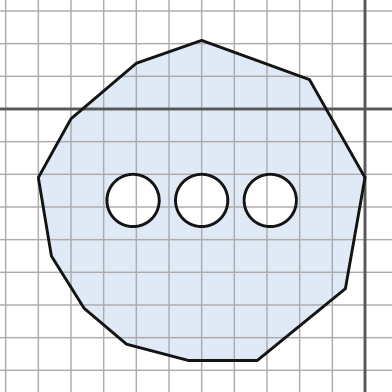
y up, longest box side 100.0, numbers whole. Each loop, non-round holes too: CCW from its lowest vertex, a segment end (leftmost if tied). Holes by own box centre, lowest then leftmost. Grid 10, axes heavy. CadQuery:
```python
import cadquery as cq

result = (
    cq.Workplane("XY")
    .moveTo(-54.0, -77.0)
    .lineTo(-33.0, -77.0)
    .lineTo(-6.0, -55.0)
    .lineTo(0.0, -21.0)
    .lineTo(-17.0, 9.0)
    .lineTo(-50.0, 21.0)
    .lineTo(-70.0, 14.0)
    .lineTo(-90.0, -3.0)
    .lineTo(-100.0, -21.0)
    .lineTo(-96.0, -45.0)
    .lineTo(-86.0, -61.0)
    .lineTo(-73.0, -72.0)
    .close()
    .moveTo(-71.0, -28.0)
    .circle(8.0)
    .moveTo(-50.0, -28.0)
    .circle(8.0)
    .moveTo(-29.0, -28.0)
    .circle(8.0)
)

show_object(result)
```